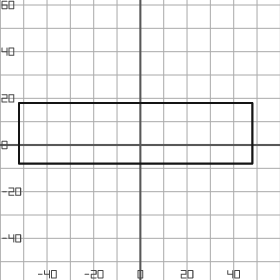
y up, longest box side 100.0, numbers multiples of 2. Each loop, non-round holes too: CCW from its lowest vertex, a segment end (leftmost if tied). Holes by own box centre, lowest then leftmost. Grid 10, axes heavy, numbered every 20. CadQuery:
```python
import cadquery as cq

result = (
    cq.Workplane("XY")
    .moveTo(-52.0, -8.0)
    .lineTo(48.0, -8.0)
    .lineTo(48.0, 18.0)
    .lineTo(-52.0, 18.0)
    .close()
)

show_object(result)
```